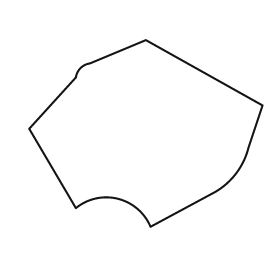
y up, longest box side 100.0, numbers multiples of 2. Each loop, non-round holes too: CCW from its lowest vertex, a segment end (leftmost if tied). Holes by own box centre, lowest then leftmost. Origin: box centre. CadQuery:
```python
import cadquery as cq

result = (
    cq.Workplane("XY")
    .moveTo(2.0, -40.0)
    .lineTo(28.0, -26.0)
    .threePointArc((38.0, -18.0), (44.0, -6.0))
    .lineTo(50.0, 12.0)
    .lineTo(0.0, 40.0)
    .lineTo(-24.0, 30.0)
    .threePointArc((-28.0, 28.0), (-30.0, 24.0))
    .lineTo(-50.0, 2.0)
    .lineTo(-30.0, -32.0)
    .threePointArc((-12.0, -28.0), (2.0, -40.0))
    .close()
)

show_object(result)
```